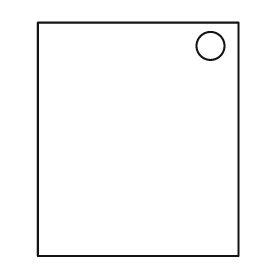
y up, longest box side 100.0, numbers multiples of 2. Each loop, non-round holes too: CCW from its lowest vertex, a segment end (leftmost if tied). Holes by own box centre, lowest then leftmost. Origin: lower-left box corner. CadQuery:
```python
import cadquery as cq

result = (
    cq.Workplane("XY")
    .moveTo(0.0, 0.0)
    .lineTo(86.0, 0.0)
    .lineTo(86.0, 100.0)
    .lineTo(0.0, 100.0)
    .close()
    .moveTo(74.0, 90.0)
    .circle(6.0)
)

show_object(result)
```